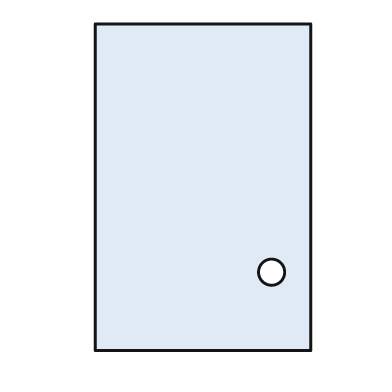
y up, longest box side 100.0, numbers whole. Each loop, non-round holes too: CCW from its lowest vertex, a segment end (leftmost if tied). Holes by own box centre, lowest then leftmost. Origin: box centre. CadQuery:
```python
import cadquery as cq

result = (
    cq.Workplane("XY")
    .moveTo(-33.0, -50.0)
    .lineTo(33.0, -50.0)
    .lineTo(33.0, 50.0)
    .lineTo(-33.0, 50.0)
    .close()
    .moveTo(21.0, -26.0)
    .circle(4.0)
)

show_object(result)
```